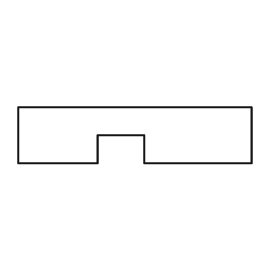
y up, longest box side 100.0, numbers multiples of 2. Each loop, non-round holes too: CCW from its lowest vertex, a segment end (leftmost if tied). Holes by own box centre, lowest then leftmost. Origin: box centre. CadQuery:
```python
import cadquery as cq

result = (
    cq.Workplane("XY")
    .moveTo(-50.0, -12.0)
    .lineTo(-16.0, -12.0)
    .lineTo(-16.0, 0.0)
    .lineTo(4.0, 0.0)
    .lineTo(4.0, -12.0)
    .lineTo(50.0, -12.0)
    .lineTo(50.0, 12.0)
    .lineTo(-50.0, 12.0)
    .close()
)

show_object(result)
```